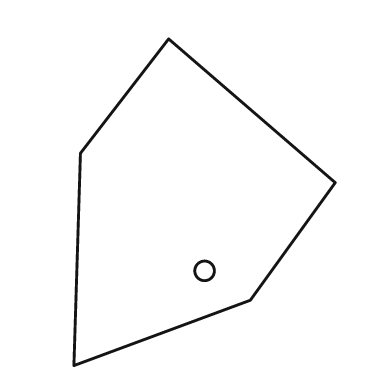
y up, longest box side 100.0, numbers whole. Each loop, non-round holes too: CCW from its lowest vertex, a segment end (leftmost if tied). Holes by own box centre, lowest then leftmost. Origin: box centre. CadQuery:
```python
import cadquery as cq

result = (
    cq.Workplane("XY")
    .moveTo(-40.0, -50.0)
    .lineTo(14.0, -30.0)
    .lineTo(40.0, 6.0)
    .lineTo(-11.0, 50.0)
    .lineTo(-38.0, 15.0)
    .close()
    .moveTo(0.0, -21.0)
    .circle(3.0)
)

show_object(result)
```